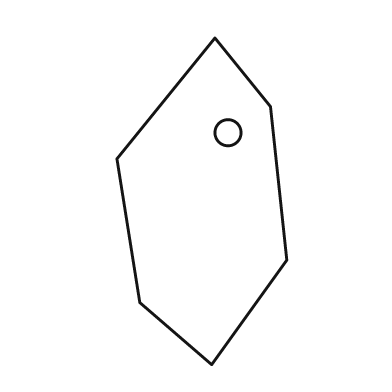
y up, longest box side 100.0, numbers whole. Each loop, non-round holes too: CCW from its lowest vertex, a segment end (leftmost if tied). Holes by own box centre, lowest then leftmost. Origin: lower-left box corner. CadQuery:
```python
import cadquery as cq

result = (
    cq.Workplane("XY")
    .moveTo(29.0, 0.0)
    .lineTo(52.0, 32.0)
    .lineTo(47.0, 79.0)
    .lineTo(30.0, 100.0)
    .lineTo(0.0, 63.0)
    .lineTo(7.0, 19.0)
    .close()
    .moveTo(34.0, 71.0)
    .circle(4.0)
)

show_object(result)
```